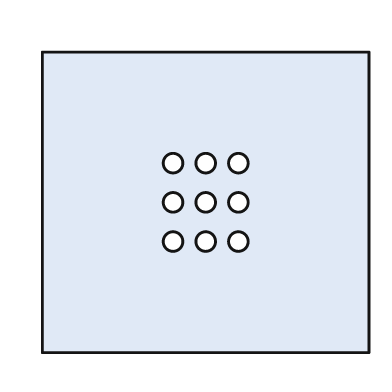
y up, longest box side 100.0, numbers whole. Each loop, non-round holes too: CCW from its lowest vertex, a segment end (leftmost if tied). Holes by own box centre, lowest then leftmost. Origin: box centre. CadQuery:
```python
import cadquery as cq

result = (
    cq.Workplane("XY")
    .moveTo(-50.0, -46.0)
    .lineTo(50.0, -46.0)
    .lineTo(50.0, 46.0)
    .lineTo(-50.0, 46.0)
    .close()
    .moveTo(-10.0, -12.0)
    .circle(3.0)
    .moveTo(0.0, -12.0)
    .circle(3.0)
    .moveTo(10.0, -12.0)
    .circle(3.0)
    .moveTo(-10.0, 0.0)
    .circle(3.0)
    .moveTo(0.0, 0.0)
    .circle(3.0)
    .moveTo(10.0, 0.0)
    .circle(3.0)
    .moveTo(-10.0, 12.0)
    .circle(3.0)
    .moveTo(0.0, 12.0)
    .circle(3.0)
    .moveTo(10.0, 12.0)
    .circle(3.0)
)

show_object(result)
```